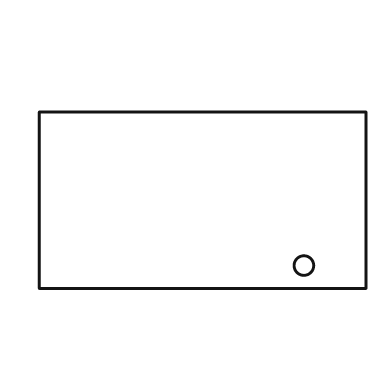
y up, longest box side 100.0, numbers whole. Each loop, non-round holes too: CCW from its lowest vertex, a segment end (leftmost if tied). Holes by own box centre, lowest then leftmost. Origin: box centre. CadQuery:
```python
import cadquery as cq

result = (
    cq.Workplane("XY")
    .moveTo(-50.0, -27.0)
    .lineTo(50.0, -27.0)
    .lineTo(50.0, 27.0)
    .lineTo(-50.0, 27.0)
    .close()
    .moveTo(31.0, -20.0)
    .circle(3.0)
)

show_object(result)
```